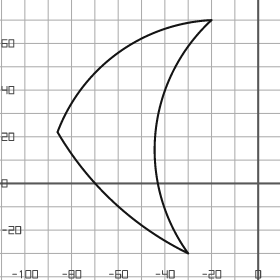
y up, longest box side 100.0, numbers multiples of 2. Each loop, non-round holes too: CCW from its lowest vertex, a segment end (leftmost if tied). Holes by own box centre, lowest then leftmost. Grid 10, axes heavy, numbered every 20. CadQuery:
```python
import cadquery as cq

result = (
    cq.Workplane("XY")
    .moveTo(-30.0, -30.0)
    .threePointArc((-44.0, 22.0), (-20.0, 70.0))
    .threePointArc((-60.0, 56.0), (-86.0, 22.0))
    .threePointArc((-62.0, -8.0), (-30.0, -30.0))
    .close()
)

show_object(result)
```